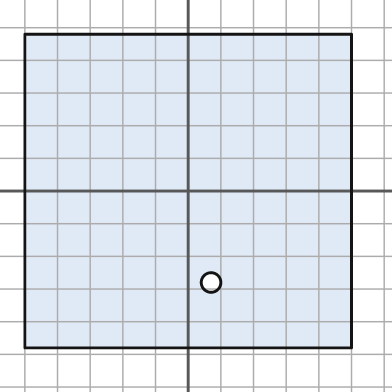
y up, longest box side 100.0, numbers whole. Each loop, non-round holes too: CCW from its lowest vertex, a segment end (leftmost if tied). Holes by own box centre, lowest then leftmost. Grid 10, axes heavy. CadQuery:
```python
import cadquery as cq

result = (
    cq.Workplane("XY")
    .moveTo(-50.0, -48.0)
    .lineTo(50.0, -48.0)
    .lineTo(50.0, 48.0)
    .lineTo(-50.0, 48.0)
    .close()
    .moveTo(7.0, -28.0)
    .circle(3.0)
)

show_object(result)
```